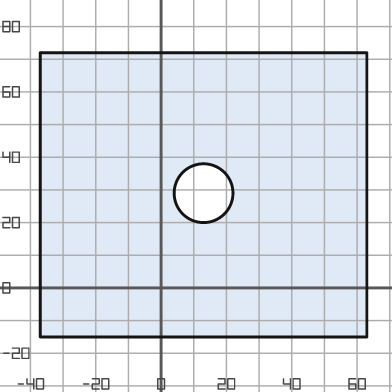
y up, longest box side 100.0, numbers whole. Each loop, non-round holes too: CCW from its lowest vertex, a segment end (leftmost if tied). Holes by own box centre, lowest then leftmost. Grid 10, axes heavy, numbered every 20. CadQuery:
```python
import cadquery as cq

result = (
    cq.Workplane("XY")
    .moveTo(-37.0, -15.0)
    .lineTo(63.0, -15.0)
    .lineTo(63.0, 72.0)
    .lineTo(-37.0, 72.0)
    .close()
    .moveTo(13.0, 29.0)
    .circle(9.0)
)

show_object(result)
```